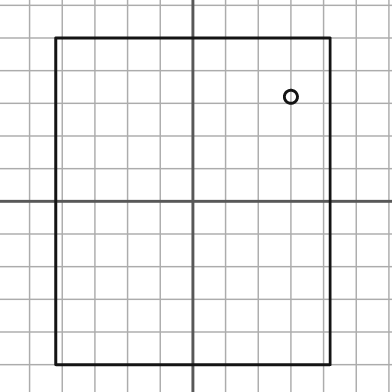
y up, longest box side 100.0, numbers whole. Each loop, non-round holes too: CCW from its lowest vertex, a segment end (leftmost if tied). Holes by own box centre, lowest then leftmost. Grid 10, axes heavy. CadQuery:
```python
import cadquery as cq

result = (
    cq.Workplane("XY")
    .moveTo(-42.0, -50.0)
    .lineTo(42.0, -50.0)
    .lineTo(42.0, 50.0)
    .lineTo(-42.0, 50.0)
    .close()
    .moveTo(30.0, 32.0)
    .circle(2.0)
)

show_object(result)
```